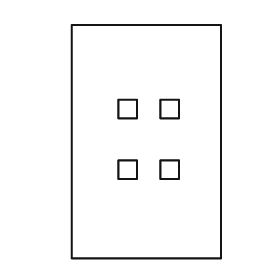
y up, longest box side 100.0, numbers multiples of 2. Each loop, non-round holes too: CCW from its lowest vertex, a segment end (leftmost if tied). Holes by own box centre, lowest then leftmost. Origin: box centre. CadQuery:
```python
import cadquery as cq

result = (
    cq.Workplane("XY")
    .moveTo(-32.0, -50.0)
    .lineTo(32.0, -50.0)
    .lineTo(32.0, 50.0)
    .lineTo(-32.0, 50.0)
    .close()
    .moveTo(-12.0, -16.0)
    .lineTo(-4.0, -16.0)
    .lineTo(-4.0, -8.0)
    .lineTo(-12.0, -8.0)
    .close()
    .moveTo(6.0, -16.0)
    .lineTo(14.0, -16.0)
    .lineTo(14.0, -8.0)
    .lineTo(6.0, -8.0)
    .close()
    .moveTo(-12.0, 10.0)
    .lineTo(-4.0, 10.0)
    .lineTo(-4.0, 18.0)
    .lineTo(-12.0, 18.0)
    .close()
    .moveTo(6.0, 10.0)
    .lineTo(14.0, 10.0)
    .lineTo(14.0, 18.0)
    .lineTo(6.0, 18.0)
    .close()
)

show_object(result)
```